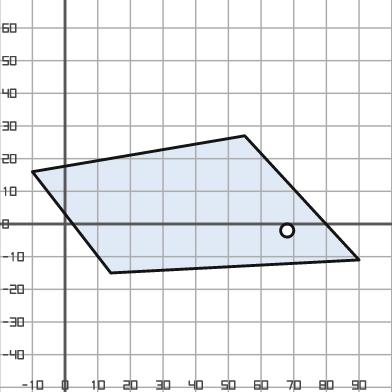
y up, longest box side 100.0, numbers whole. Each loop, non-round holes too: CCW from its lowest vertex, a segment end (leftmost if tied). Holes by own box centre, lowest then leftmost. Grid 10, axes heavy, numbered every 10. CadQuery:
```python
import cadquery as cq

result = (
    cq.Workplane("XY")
    .moveTo(14.0, -15.0)
    .lineTo(90.0, -11.0)
    .lineTo(55.0, 27.0)
    .lineTo(-10.0, 16.0)
    .close()
    .moveTo(68.0, -2.0)
    .circle(2.0)
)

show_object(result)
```